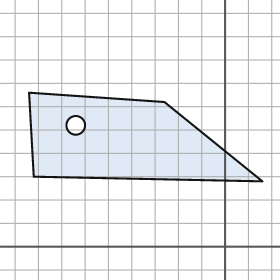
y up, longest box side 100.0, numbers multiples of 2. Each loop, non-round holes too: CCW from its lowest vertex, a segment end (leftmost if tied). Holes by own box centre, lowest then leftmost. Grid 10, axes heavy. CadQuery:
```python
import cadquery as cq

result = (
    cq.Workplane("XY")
    .moveTo(16.0, 28.0)
    .lineTo(-26.0, 62.0)
    .lineTo(-84.0, 66.0)
    .lineTo(-82.0, 30.0)
    .close()
    .moveTo(-64.0, 52.0)
    .circle(4.0)
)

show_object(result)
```